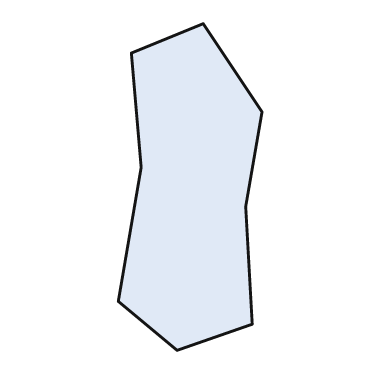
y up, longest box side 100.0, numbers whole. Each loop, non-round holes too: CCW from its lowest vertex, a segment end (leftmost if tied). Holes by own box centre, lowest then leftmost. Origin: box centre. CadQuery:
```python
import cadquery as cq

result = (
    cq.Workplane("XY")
    .moveTo(-4.0, -50.0)
    .lineTo(19.0, -42.0)
    .lineTo(17.0, -6.0)
    .lineTo(22.0, 23.0)
    .lineTo(4.0, 50.0)
    .lineTo(-18.0, 41.0)
    .lineTo(-15.0, 6.0)
    .lineTo(-22.0, -35.0)
    .close()
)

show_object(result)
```